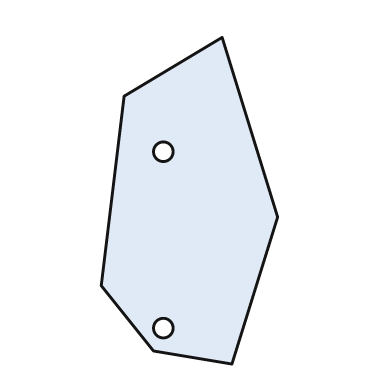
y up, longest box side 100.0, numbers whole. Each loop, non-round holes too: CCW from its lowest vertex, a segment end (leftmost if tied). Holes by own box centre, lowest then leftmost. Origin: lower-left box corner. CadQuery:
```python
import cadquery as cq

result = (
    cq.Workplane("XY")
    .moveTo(40.0, 0.0)
    .lineTo(54.0, 45.0)
    .lineTo(37.0, 100.0)
    .lineTo(7.0, 82.0)
    .lineTo(0.0, 24.0)
    .lineTo(16.0, 4.0)
    .close()
    .moveTo(19.0, 11.0)
    .circle(3.0)
    .moveTo(19.0, 65.0)
    .circle(3.0)
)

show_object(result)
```